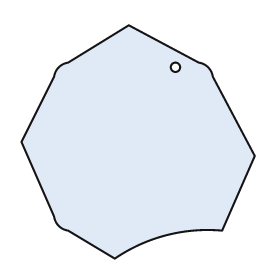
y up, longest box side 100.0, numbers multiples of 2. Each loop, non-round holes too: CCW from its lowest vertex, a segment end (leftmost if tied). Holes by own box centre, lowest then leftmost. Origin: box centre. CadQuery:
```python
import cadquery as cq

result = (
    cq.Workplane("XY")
    .moveTo(-10.0, -50.0)
    .threePointArc((12.0, -40.0), (36.0, -38.0))
    .lineTo(50.0, -6.0)
    .lineTo(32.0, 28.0)
    .threePointArc((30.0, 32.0), (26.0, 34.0))
    .lineTo(-4.0, 50.0)
    .lineTo(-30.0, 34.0)
    .threePointArc((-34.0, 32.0), (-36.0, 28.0))
    .lineTo(-50.0, 0.0)
    .lineTo(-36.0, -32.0)
    .threePointArc((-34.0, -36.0), (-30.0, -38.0))
    .close()
    .moveTo(16.0, 32.0)
    .circle(2.0)
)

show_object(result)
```